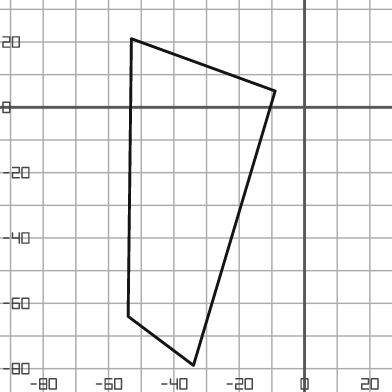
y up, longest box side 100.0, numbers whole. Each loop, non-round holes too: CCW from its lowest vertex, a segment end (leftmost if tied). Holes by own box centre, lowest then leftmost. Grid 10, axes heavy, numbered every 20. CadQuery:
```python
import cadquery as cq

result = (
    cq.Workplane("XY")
    .moveTo(-34.0, -79.0)
    .lineTo(-9.0, 5.0)
    .lineTo(-53.0, 21.0)
    .lineTo(-54.0, -64.0)
    .close()
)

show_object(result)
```